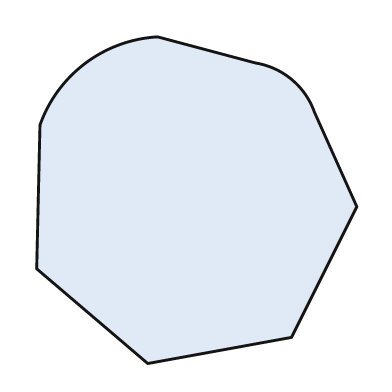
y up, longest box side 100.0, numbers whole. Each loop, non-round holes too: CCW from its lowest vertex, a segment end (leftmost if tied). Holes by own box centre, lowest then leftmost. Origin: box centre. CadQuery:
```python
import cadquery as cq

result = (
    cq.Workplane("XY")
    .moveTo(-15.0, -50.0)
    .lineTo(29.0, -42.0)
    .lineTo(49.0, -2.0)
    .lineTo(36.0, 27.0)
    .threePointArc((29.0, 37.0), (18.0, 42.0))
    .lineTo(-12.0, 50.0)
    .threePointArc((-34.0, 42.0), (-48.0, 23.0))
    .lineTo(-49.0, -21.0)
    .close()
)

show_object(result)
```